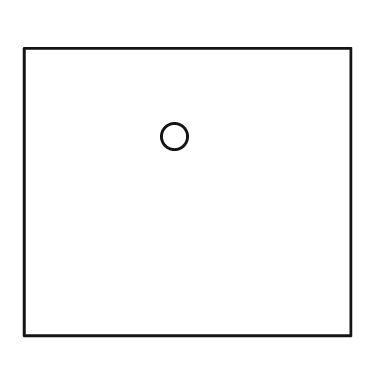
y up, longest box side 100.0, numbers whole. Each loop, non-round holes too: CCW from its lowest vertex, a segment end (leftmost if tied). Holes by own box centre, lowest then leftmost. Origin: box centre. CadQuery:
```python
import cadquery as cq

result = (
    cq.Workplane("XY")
    .moveTo(-50.0, -44.0)
    .lineTo(50.0, -44.0)
    .lineTo(50.0, 44.0)
    .lineTo(-50.0, 44.0)
    .close()
    .moveTo(-4.0, 17.0)
    .circle(4.0)
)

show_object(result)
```